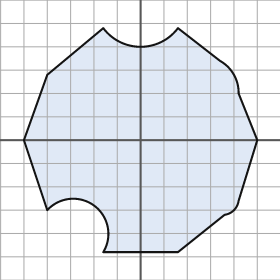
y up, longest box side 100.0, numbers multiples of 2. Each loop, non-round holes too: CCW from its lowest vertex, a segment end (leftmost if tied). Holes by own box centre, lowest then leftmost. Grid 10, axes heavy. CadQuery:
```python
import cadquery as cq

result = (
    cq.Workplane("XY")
    .moveTo(-16.0, -48.0)
    .lineTo(16.0, -48.0)
    .lineTo(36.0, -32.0)
    .threePointArc((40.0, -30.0), (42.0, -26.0))
    .lineTo(50.0, 0.0)
    .lineTo(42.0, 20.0)
    .threePointArc((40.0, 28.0), (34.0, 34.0))
    .lineTo(16.0, 48.0)
    .threePointArc((0.0, 40.0), (-16.0, 48.0))
    .lineTo(-40.0, 28.0)
    .lineTo(-50.0, 0.0)
    .lineTo(-40.0, -30.0)
    .threePointArc((-20.0, -28.0), (-16.0, -48.0))
    .close()
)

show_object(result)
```